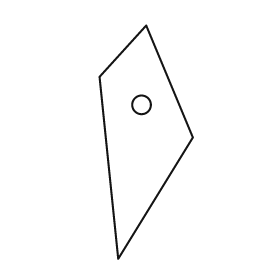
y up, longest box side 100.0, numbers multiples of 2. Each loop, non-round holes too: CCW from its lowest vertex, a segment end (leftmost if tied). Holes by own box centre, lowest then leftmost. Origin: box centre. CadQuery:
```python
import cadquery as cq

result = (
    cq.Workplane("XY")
    .moveTo(-12.0, -50.0)
    .lineTo(20.0, 2.0)
    .lineTo(0.0, 50.0)
    .lineTo(-20.0, 28.0)
    .close()
    .moveTo(-2.0, 16.0)
    .circle(4.0)
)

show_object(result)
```